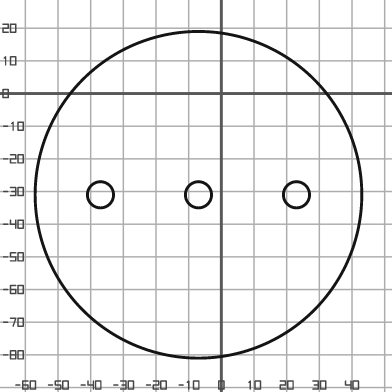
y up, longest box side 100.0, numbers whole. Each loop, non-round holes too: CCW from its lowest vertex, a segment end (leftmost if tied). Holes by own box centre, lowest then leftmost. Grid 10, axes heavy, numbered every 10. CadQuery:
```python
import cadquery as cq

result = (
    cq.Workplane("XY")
    .moveTo(-7.0, -31.0)
    .circle(50.0)
    .moveTo(-37.0, -31.0)
    .circle(4.0)
    .moveTo(-7.0, -31.0)
    .circle(4.0)
    .moveTo(23.0, -31.0)
    .circle(4.0)
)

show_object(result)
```